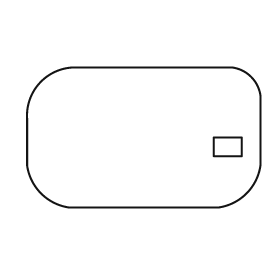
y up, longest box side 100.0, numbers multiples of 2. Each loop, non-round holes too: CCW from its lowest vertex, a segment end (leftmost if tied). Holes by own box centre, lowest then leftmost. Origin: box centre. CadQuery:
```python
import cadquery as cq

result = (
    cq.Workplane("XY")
    .moveTo(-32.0, -30.0)
    .lineTo(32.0, -30.0)
    .threePointArc((44.0, -24.0), (50.0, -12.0))
    .lineTo(50.0, 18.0)
    .threePointArc((46.0, 26.0), (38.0, 30.0))
    .lineTo(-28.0, 30.0)
    .threePointArc((-44.0, 24.0), (-50.0, 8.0))
    .lineTo(-50.0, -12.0)
    .threePointArc((-44.0, -24.0), (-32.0, -30.0))
    .close()
    .moveTo(30.0, -8.0)
    .lineTo(42.0, -8.0)
    .lineTo(42.0, 0.0)
    .lineTo(30.0, 0.0)
    .close()
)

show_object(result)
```